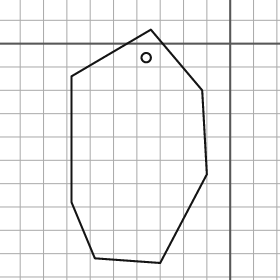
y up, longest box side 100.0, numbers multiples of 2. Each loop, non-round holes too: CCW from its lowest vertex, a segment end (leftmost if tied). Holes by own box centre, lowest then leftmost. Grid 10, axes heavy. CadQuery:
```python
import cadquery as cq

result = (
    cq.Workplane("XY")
    .moveTo(-30.0, -94.0)
    .lineTo(-10.0, -56.0)
    .lineTo(-12.0, -20.0)
    .lineTo(-34.0, 6.0)
    .lineTo(-68.0, -14.0)
    .lineTo(-68.0, -68.0)
    .lineTo(-58.0, -92.0)
    .close()
    .moveTo(-36.0, -6.0)
    .circle(2.0)
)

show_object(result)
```